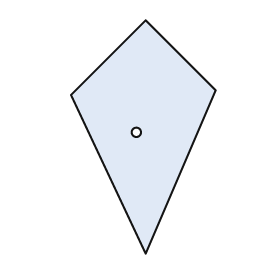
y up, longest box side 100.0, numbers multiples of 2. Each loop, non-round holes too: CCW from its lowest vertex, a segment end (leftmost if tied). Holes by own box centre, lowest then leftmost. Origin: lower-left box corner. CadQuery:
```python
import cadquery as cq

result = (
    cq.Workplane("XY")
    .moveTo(32.0, 0.0)
    .lineTo(62.0, 70.0)
    .lineTo(32.0, 100.0)
    .lineTo(0.0, 68.0)
    .close()
    .moveTo(28.0, 52.0)
    .circle(2.0)
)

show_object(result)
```